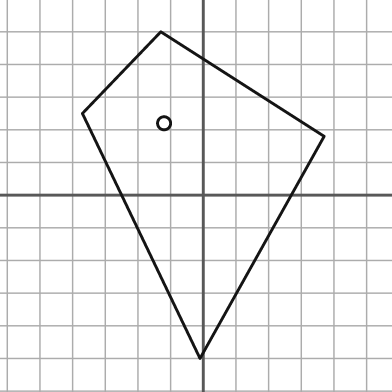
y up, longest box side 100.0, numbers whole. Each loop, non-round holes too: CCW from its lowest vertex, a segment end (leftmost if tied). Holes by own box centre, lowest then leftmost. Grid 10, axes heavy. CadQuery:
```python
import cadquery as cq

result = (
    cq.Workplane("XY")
    .moveTo(-1.0, -50.0)
    .lineTo(37.0, 18.0)
    .lineTo(-13.0, 50.0)
    .lineTo(-37.0, 25.0)
    .close()
    .moveTo(-12.0, 22.0)
    .circle(2.0)
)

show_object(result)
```